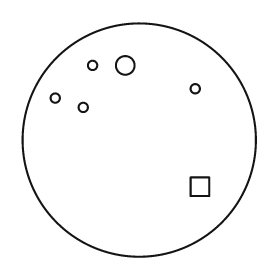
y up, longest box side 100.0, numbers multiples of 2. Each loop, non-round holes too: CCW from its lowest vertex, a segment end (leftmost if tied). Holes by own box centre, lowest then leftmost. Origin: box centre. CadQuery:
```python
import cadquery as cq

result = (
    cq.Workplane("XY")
    .moveTo(0.0, 0.0)
    .circle(50.0)
    .moveTo(22.0, -24.0)
    .lineTo(30.0, -24.0)
    .lineTo(30.0, -16.0)
    .lineTo(22.0, -16.0)
    .close()
    .moveTo(-24.0, 14.0)
    .circle(2.0)
    .moveTo(-36.0, 18.0)
    .circle(2.0)
    .moveTo(24.0, 22.0)
    .circle(2.0)
    .moveTo(-20.0, 32.0)
    .circle(2.0)
    .moveTo(-6.0, 32.0)
    .circle(4.0)
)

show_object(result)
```